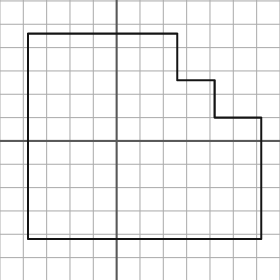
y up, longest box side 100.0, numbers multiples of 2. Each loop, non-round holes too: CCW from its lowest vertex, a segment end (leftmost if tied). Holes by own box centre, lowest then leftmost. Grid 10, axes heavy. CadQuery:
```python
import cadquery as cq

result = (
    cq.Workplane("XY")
    .moveTo(-38.0, -42.0)
    .lineTo(62.0, -42.0)
    .lineTo(62.0, 10.0)
    .lineTo(42.0, 10.0)
    .lineTo(42.0, 26.0)
    .lineTo(26.0, 26.0)
    .lineTo(26.0, 46.0)
    .lineTo(-38.0, 46.0)
    .close()
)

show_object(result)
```